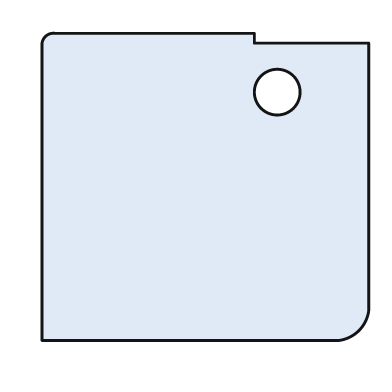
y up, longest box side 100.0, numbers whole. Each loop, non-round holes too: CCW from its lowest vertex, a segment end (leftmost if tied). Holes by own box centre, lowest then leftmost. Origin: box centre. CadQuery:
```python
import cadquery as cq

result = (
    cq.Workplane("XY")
    .moveTo(-50.0, -47.0)
    .lineTo(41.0, -47.0)
    .threePointArc((47.0, -44.0), (50.0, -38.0))
    .lineTo(50.0, 44.0)
    .lineTo(15.0, 44.0)
    .lineTo(15.0, 47.0)
    .lineTo(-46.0, 47.0)
    .threePointArc((-49.0, 46.0), (-50.0, 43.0))
    .close()
    .moveTo(22.0, 29.0)
    .circle(7.0)
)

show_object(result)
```